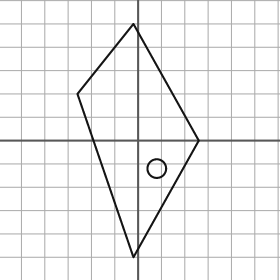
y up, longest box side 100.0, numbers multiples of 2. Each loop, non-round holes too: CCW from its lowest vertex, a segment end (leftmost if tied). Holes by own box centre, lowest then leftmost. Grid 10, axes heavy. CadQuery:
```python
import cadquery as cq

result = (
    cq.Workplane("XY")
    .moveTo(-2.0, -50.0)
    .lineTo(26.0, 0.0)
    .lineTo(-2.0, 50.0)
    .lineTo(-26.0, 20.0)
    .close()
    .moveTo(8.0, -12.0)
    .circle(4.0)
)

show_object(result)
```